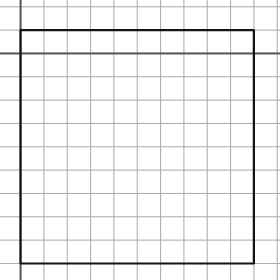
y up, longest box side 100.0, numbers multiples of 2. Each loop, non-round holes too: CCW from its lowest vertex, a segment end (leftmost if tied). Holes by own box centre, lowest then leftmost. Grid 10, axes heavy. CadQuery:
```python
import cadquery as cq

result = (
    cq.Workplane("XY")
    .moveTo(0.0, -90.0)
    .lineTo(100.0, -90.0)
    .lineTo(100.0, 10.0)
    .lineTo(0.0, 10.0)
    .close()
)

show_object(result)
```